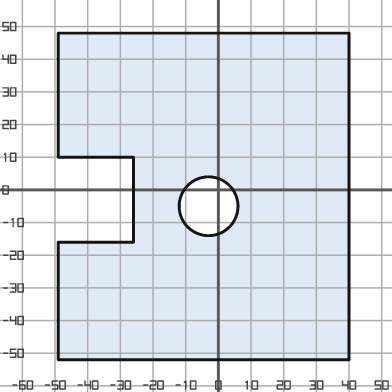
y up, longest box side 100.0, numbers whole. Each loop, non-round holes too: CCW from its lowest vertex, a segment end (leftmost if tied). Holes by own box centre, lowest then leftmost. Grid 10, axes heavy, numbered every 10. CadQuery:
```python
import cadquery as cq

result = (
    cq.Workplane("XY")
    .moveTo(-49.0, -52.0)
    .lineTo(40.0, -52.0)
    .lineTo(40.0, 48.0)
    .lineTo(-49.0, 48.0)
    .lineTo(-49.0, 10.0)
    .lineTo(-26.0, 10.0)
    .lineTo(-26.0, -16.0)
    .lineTo(-49.0, -16.0)
    .close()
    .moveTo(-3.0, -5.0)
    .circle(9.0)
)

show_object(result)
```